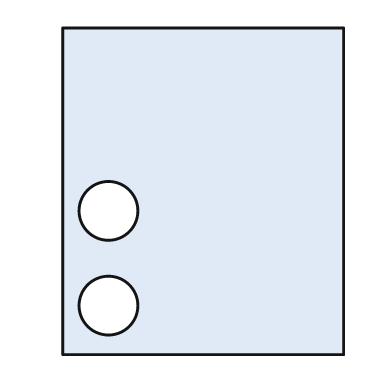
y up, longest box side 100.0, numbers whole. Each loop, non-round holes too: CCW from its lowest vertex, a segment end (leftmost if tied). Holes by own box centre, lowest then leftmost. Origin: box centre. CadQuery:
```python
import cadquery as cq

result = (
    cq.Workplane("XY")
    .moveTo(-43.0, -50.0)
    .lineTo(43.0, -50.0)
    .lineTo(43.0, 50.0)
    .lineTo(-43.0, 50.0)
    .close()
    .moveTo(-29.0, -35.0)
    .circle(9.0)
    .moveTo(-29.0, -6.0)
    .circle(9.0)
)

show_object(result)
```